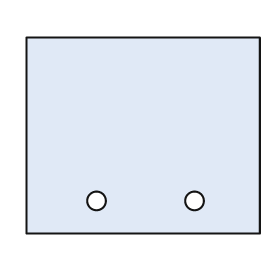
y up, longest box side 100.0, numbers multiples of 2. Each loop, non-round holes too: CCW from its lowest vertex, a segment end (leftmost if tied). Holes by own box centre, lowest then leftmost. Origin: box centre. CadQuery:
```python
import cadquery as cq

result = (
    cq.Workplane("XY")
    .moveTo(-50.0, -42.0)
    .lineTo(50.0, -42.0)
    .lineTo(50.0, 42.0)
    .lineTo(-50.0, 42.0)
    .close()
    .moveTo(-20.0, -28.0)
    .circle(4.0)
    .moveTo(22.0, -28.0)
    .circle(4.0)
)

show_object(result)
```